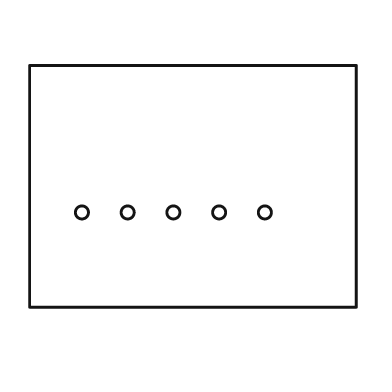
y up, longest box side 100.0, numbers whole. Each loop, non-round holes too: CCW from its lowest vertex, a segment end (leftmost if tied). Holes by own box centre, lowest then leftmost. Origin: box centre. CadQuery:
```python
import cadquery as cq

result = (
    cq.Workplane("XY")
    .moveTo(-50.0, -37.0)
    .lineTo(50.0, -37.0)
    .lineTo(50.0, 37.0)
    .lineTo(-50.0, 37.0)
    .close()
    .moveTo(-34.0, -8.0)
    .circle(2.0)
    .moveTo(-20.0, -8.0)
    .circle(2.0)
    .moveTo(-6.0, -8.0)
    .circle(2.0)
    .moveTo(8.0, -8.0)
    .circle(2.0)
    .moveTo(22.0, -8.0)
    .circle(2.0)
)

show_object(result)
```